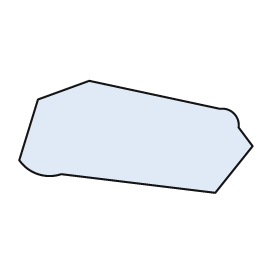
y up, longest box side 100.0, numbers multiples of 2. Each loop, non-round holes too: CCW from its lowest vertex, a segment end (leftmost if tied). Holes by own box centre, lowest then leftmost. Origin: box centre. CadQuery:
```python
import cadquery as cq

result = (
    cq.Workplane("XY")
    .moveTo(34.0, -24.0)
    .lineTo(50.0, -4.0)
    .lineTo(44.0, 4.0)
    .threePointArc((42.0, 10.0), (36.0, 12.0))
    .lineTo(-20.0, 24.0)
    .lineTo(-42.0, 16.0)
    .lineTo(-50.0, -10.0)
    .threePointArc((-42.0, -16.0), (-32.0, -16.0))
    .close()
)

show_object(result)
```